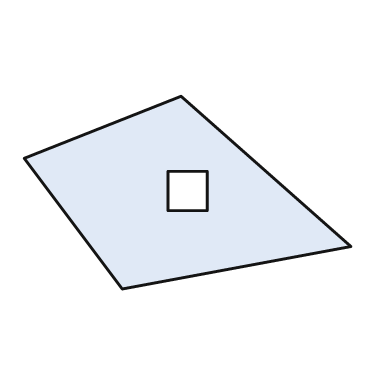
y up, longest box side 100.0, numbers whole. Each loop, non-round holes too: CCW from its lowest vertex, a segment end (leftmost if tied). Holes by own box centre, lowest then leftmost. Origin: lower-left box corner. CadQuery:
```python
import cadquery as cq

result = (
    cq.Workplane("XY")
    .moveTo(30.0, 0.0)
    .lineTo(100.0, 13.0)
    .lineTo(48.0, 59.0)
    .lineTo(0.0, 40.0)
    .close()
    .moveTo(44.0, 24.0)
    .lineTo(56.0, 24.0)
    .lineTo(56.0, 36.0)
    .lineTo(44.0, 36.0)
    .close()
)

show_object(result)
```